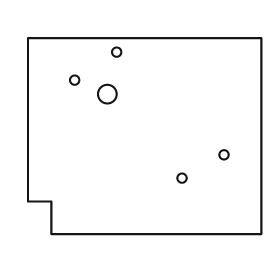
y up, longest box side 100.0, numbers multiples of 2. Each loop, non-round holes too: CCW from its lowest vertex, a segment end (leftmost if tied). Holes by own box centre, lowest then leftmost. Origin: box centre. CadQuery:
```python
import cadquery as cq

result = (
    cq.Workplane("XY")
    .moveTo(-40.0, -42.0)
    .lineTo(50.0, -42.0)
    .lineTo(50.0, 42.0)
    .lineTo(-50.0, 42.0)
    .lineTo(-50.0, -28.0)
    .lineTo(-40.0, -28.0)
    .close()
    .moveTo(16.0, -18.0)
    .circle(2.0)
    .moveTo(34.0, -8.0)
    .circle(2.0)
    .moveTo(-16.0, 18.0)
    .circle(4.0)
    .moveTo(-30.0, 24.0)
    .circle(2.0)
    .moveTo(-12.0, 36.0)
    .circle(2.0)
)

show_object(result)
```